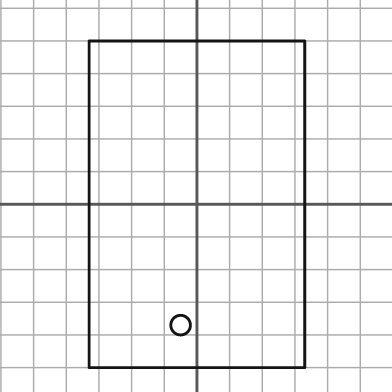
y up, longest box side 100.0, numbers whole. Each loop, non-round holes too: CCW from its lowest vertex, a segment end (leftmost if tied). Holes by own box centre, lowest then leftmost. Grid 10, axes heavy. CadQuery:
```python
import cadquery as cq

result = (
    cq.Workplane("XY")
    .moveTo(-33.0, -50.0)
    .lineTo(33.0, -50.0)
    .lineTo(33.0, 50.0)
    .lineTo(-33.0, 50.0)
    .close()
    .moveTo(-5.0, -37.0)
    .circle(3.0)
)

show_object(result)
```